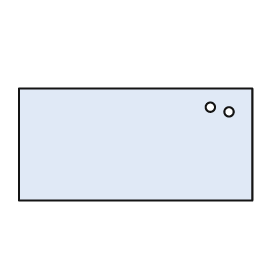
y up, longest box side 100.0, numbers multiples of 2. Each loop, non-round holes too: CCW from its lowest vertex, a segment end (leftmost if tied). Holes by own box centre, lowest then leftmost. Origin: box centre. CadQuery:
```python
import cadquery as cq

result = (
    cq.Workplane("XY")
    .moveTo(-50.0, -24.0)
    .lineTo(50.0, -24.0)
    .lineTo(50.0, 24.0)
    .lineTo(-50.0, 24.0)
    .close()
    .moveTo(40.0, 14.0)
    .circle(2.0)
    .moveTo(32.0, 16.0)
    .circle(2.0)
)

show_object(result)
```